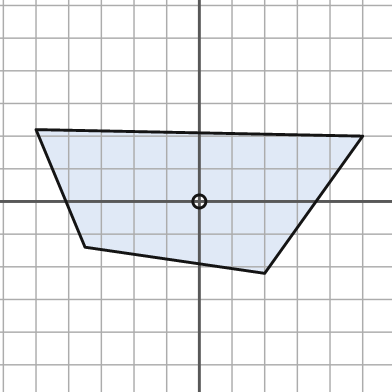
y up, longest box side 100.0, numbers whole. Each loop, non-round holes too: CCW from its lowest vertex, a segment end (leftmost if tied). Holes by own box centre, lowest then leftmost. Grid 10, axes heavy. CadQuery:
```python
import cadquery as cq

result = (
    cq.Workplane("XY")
    .moveTo(20.0, -22.0)
    .lineTo(50.0, 20.0)
    .lineTo(-50.0, 22.0)
    .lineTo(-35.0, -14.0)
    .close()
    .moveTo(0.0, 0.0)
    .circle(2.0)
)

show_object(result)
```